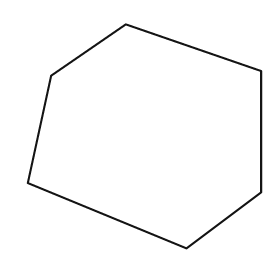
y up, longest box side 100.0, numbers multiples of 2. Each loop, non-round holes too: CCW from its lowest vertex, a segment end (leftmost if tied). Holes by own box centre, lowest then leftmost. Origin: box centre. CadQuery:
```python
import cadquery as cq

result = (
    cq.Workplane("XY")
    .moveTo(18.0, -48.0)
    .lineTo(50.0, -24.0)
    .lineTo(50.0, 28.0)
    .lineTo(-8.0, 48.0)
    .lineTo(-40.0, 26.0)
    .lineTo(-50.0, -20.0)
    .close()
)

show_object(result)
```